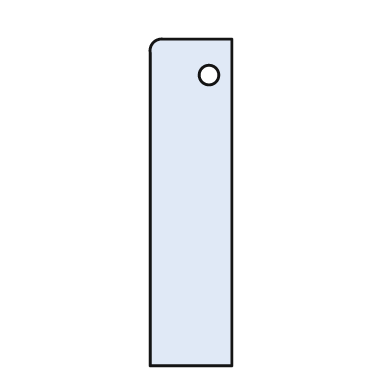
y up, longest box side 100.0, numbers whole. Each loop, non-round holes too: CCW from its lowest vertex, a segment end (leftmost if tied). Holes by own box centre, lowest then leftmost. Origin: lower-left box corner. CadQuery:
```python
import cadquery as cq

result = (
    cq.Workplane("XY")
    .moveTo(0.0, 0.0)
    .lineTo(25.0, 0.0)
    .lineTo(25.0, 100.0)
    .lineTo(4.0, 100.0)
    .threePointArc((1.0, 99.0), (0.0, 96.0))
    .close()
    .moveTo(18.0, 89.0)
    .circle(3.0)
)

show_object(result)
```